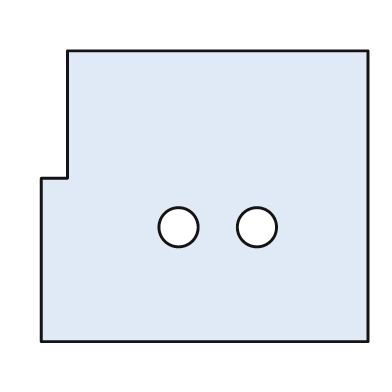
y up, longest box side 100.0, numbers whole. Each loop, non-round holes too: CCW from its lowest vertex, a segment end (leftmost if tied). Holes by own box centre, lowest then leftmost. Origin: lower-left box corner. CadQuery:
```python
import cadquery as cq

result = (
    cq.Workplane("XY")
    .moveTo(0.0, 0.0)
    .lineTo(100.0, 0.0)
    .lineTo(100.0, 89.0)
    .lineTo(8.0, 89.0)
    .lineTo(8.0, 50.0)
    .lineTo(0.0, 50.0)
    .close()
    .moveTo(42.0, 35.0)
    .circle(6.0)
    .moveTo(66.0, 35.0)
    .circle(6.0)
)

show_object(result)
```